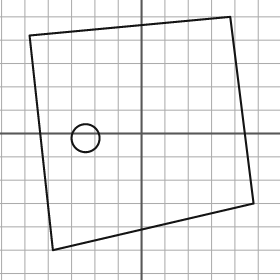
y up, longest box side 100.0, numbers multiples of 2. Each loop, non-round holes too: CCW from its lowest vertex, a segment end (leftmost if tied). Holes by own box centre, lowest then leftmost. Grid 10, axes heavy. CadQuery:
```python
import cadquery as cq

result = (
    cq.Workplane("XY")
    .moveTo(-38.0, -50.0)
    .lineTo(48.0, -30.0)
    .lineTo(38.0, 50.0)
    .lineTo(-48.0, 42.0)
    .close()
    .moveTo(-24.0, -2.0)
    .circle(6.0)
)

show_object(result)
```